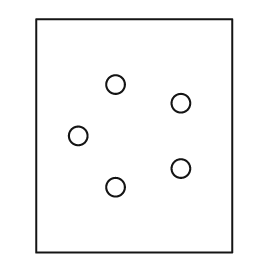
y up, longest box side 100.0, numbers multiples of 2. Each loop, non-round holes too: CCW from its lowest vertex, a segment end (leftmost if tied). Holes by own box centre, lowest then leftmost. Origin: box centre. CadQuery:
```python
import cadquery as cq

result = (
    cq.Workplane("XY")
    .moveTo(-42.0, -50.0)
    .lineTo(42.0, -50.0)
    .lineTo(42.0, 50.0)
    .lineTo(-42.0, 50.0)
    .close()
    .moveTo(-8.0, -22.0)
    .circle(4.0)
    .moveTo(20.0, -14.0)
    .circle(4.0)
    .moveTo(-24.0, 0.0)
    .circle(4.0)
    .moveTo(20.0, 14.0)
    .circle(4.0)
    .moveTo(-8.0, 22.0)
    .circle(4.0)
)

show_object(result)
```